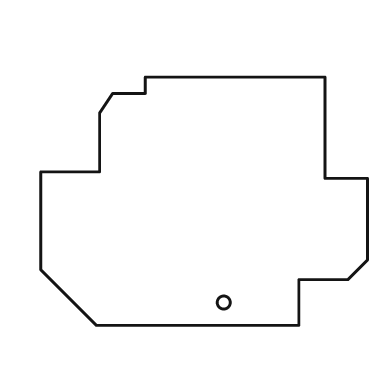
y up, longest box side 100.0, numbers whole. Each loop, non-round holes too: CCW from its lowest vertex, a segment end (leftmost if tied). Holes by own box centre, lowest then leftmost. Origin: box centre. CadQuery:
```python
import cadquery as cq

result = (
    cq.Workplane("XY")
    .moveTo(-33.0, -38.0)
    .lineTo(29.0, -38.0)
    .lineTo(29.0, -24.0)
    .lineTo(44.0, -24.0)
    .lineTo(50.0, -18.0)
    .lineTo(50.0, 7.0)
    .lineTo(37.0, 7.0)
    .lineTo(37.0, 38.0)
    .lineTo(-18.0, 38.0)
    .lineTo(-18.0, 33.0)
    .lineTo(-28.0, 33.0)
    .lineTo(-32.0, 27.0)
    .lineTo(-32.0, 9.0)
    .lineTo(-50.0, 9.0)
    .lineTo(-50.0, -21.0)
    .close()
    .moveTo(6.0, -31.0)
    .circle(2.0)
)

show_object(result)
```